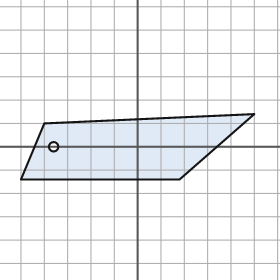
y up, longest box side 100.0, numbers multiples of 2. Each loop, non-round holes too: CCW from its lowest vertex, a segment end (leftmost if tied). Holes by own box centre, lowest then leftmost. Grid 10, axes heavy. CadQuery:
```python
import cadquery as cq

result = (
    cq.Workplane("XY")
    .moveTo(-50.0, -14.0)
    .lineTo(18.0, -14.0)
    .lineTo(50.0, 14.0)
    .lineTo(-40.0, 10.0)
    .close()
    .moveTo(-36.0, 0.0)
    .circle(2.0)
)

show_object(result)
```